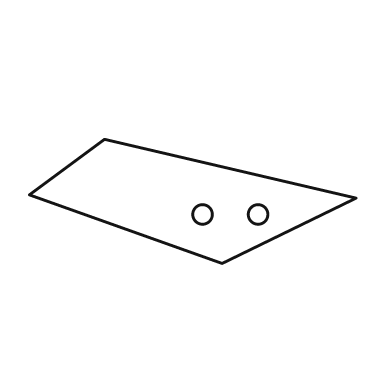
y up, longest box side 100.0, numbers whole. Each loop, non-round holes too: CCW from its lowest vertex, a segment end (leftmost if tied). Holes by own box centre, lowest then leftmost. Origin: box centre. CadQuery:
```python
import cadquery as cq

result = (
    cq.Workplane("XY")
    .moveTo(9.0, -19.0)
    .lineTo(50.0, 1.0)
    .lineTo(-27.0, 19.0)
    .lineTo(-50.0, 2.0)
    .close()
    .moveTo(3.0, -4.0)
    .circle(3.0)
    .moveTo(20.0, -4.0)
    .circle(3.0)
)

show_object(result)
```